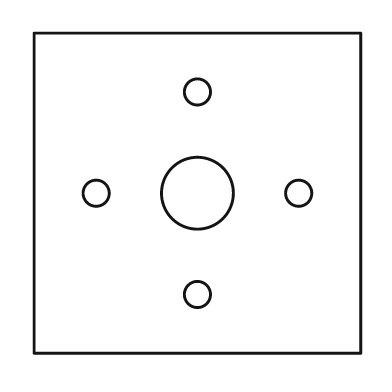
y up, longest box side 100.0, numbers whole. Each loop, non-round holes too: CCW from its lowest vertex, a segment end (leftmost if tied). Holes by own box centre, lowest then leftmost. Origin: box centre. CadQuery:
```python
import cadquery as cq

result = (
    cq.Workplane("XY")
    .moveTo(-50.0, -49.0)
    .lineTo(50.0, -49.0)
    .lineTo(50.0, 49.0)
    .lineTo(-50.0, 49.0)
    .close()
    .moveTo(0.0, -31.0)
    .circle(4.0)
    .moveTo(-31.0, 0.0)
    .circle(4.0)
    .moveTo(0.0, 0.0)
    .circle(11.0)
    .moveTo(31.0, 0.0)
    .circle(4.0)
    .moveTo(0.0, 31.0)
    .circle(4.0)
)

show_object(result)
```